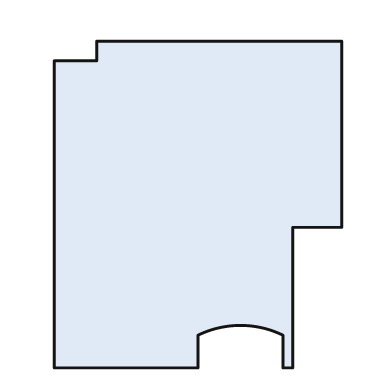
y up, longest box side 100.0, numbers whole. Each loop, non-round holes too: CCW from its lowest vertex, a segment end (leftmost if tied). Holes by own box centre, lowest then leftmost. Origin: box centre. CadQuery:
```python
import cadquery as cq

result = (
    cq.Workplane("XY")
    .moveTo(-44.0, -50.0)
    .lineTo(0.0, -50.0)
    .lineTo(0.0, -40.0)
    .threePointArc((13.0, -37.0), (26.0, -40.0))
    .lineTo(26.0, -50.0)
    .lineTo(29.0, -50.0)
    .lineTo(29.0, -7.0)
    .lineTo(44.0, -7.0)
    .lineTo(44.0, 50.0)
    .lineTo(-31.0, 50.0)
    .lineTo(-31.0, 44.0)
    .lineTo(-44.0, 44.0)
    .close()
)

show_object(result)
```